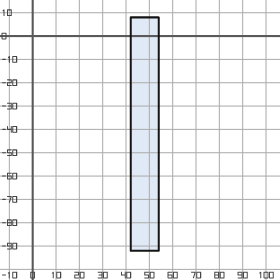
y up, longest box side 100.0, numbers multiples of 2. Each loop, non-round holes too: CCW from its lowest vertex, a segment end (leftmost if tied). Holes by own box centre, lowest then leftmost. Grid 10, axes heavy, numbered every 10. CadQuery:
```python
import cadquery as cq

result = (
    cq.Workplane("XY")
    .moveTo(42.0, -92.0)
    .lineTo(54.0, -92.0)
    .lineTo(54.0, 8.0)
    .lineTo(42.0, 8.0)
    .close()
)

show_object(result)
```